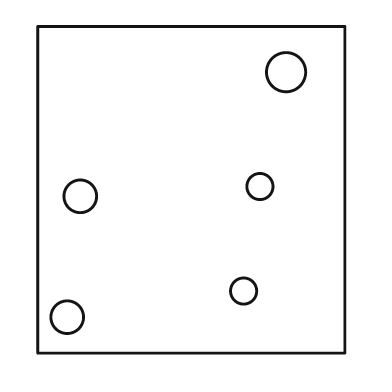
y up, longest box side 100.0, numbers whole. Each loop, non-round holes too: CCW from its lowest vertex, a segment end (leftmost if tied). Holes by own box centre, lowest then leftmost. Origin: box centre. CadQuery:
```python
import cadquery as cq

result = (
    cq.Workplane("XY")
    .moveTo(-47.0, -50.0)
    .lineTo(47.0, -50.0)
    .lineTo(47.0, 50.0)
    .lineTo(-47.0, 50.0)
    .close()
    .moveTo(-38.0, -39.0)
    .circle(5.0)
    .moveTo(16.0, -31.0)
    .circle(4.0)
    .moveTo(-34.0, -2.0)
    .circle(5.0)
    .moveTo(21.0, 1.0)
    .circle(4.0)
    .moveTo(29.0, 36.0)
    .circle(6.0)
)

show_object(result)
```